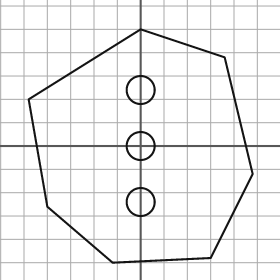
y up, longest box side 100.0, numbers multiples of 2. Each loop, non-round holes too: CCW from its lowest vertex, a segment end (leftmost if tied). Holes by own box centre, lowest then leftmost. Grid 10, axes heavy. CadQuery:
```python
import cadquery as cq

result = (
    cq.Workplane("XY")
    .moveTo(-12.0, -50.0)
    .lineTo(30.0, -48.0)
    .lineTo(48.0, -12.0)
    .lineTo(36.0, 38.0)
    .lineTo(0.0, 50.0)
    .lineTo(-48.0, 20.0)
    .lineTo(-40.0, -26.0)
    .close()
    .moveTo(0.0, -24.0)
    .circle(6.0)
    .moveTo(0.0, 0.0)
    .circle(6.0)
    .moveTo(0.0, 24.0)
    .circle(6.0)
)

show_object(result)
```